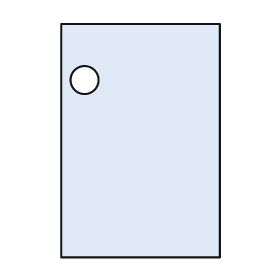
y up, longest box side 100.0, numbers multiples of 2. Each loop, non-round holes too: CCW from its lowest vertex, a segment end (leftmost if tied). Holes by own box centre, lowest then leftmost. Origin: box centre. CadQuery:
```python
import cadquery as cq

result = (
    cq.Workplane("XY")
    .moveTo(-34.0, -50.0)
    .lineTo(34.0, -50.0)
    .lineTo(34.0, 50.0)
    .lineTo(-34.0, 50.0)
    .close()
    .moveTo(-24.0, 26.0)
    .circle(6.0)
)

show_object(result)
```